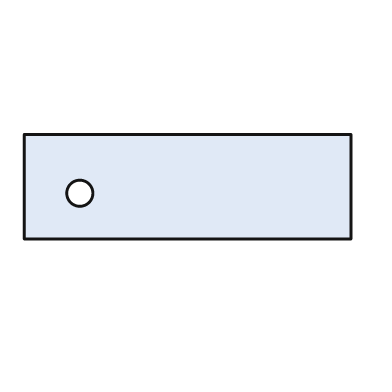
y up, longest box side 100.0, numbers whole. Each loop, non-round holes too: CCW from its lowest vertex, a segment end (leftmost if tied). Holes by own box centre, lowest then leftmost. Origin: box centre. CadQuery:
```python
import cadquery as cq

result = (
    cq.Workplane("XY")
    .moveTo(-50.0, -16.0)
    .lineTo(50.0, -16.0)
    .lineTo(50.0, 16.0)
    .lineTo(-50.0, 16.0)
    .close()
    .moveTo(-33.0, -2.0)
    .circle(4.0)
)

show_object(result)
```